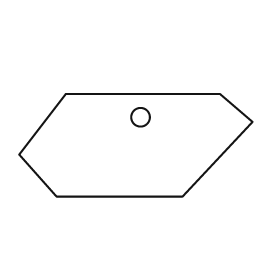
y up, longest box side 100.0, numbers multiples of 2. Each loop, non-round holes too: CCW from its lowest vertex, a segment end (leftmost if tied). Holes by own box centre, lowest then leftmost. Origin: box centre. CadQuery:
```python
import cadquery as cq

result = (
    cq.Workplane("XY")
    .moveTo(-34.0, -22.0)
    .lineTo(20.0, -22.0)
    .lineTo(50.0, 10.0)
    .lineTo(36.0, 22.0)
    .lineTo(-30.0, 22.0)
    .lineTo(-50.0, -4.0)
    .close()
    .moveTo(2.0, 12.0)
    .circle(4.0)
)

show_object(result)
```